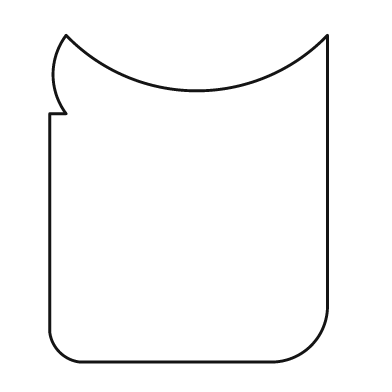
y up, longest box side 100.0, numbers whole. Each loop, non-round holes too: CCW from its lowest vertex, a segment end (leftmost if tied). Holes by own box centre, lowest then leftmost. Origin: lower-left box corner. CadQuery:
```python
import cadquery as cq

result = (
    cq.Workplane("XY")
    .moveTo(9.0, 0.0)
    .lineTo(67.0, 0.0)
    .threePointArc((80.0, 5.0), (85.0, 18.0))
    .lineTo(85.0, 100.0)
    .threePointArc((45.0, 83.0), (5.0, 100.0))
    .threePointArc((1.0, 88.0), (5.0, 76.0))
    .lineTo(0.0, 76.0)
    .lineTo(0.0, 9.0)
    .threePointArc((3.0, 3.0), (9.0, 0.0))
    .close()
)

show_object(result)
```